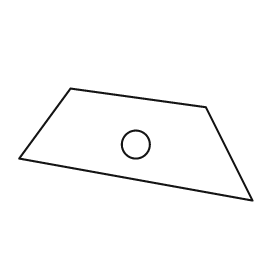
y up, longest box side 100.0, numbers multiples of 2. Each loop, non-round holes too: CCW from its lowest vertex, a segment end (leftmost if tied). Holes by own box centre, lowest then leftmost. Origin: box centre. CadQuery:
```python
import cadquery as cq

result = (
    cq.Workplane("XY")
    .moveTo(50.0, -24.0)
    .lineTo(30.0, 16.0)
    .lineTo(-28.0, 24.0)
    .lineTo(-50.0, -6.0)
    .close()
    .moveTo(0.0, 0.0)
    .circle(6.0)
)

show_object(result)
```